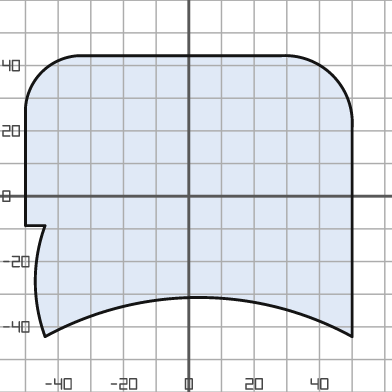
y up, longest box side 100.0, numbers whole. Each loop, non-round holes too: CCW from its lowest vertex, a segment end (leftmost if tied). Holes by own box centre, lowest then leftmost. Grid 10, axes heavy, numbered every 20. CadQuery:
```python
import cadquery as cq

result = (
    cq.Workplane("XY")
    .moveTo(-44.0, -43.0)
    .threePointArc((3.0, -31.0), (50.0, -43.0))
    .lineTo(50.0, 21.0)
    .threePointArc((44.0, 37.0), (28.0, 43.0))
    .lineTo(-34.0, 43.0)
    .threePointArc((-45.0, 38.0), (-50.0, 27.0))
    .lineTo(-50.0, -9.0)
    .lineTo(-44.0, -9.0)
    .threePointArc((-47.0, -26.0), (-44.0, -43.0))
    .close()
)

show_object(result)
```